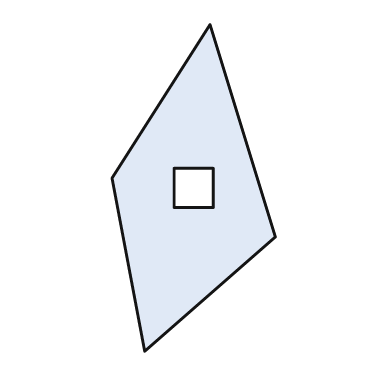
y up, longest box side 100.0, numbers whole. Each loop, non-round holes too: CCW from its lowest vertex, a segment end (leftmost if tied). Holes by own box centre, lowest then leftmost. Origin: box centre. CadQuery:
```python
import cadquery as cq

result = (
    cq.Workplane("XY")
    .moveTo(-15.0, -50.0)
    .lineTo(25.0, -15.0)
    .lineTo(5.0, 50.0)
    .lineTo(-25.0, 3.0)
    .close()
    .moveTo(-6.0, -6.0)
    .lineTo(6.0, -6.0)
    .lineTo(6.0, 6.0)
    .lineTo(-6.0, 6.0)
    .close()
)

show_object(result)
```